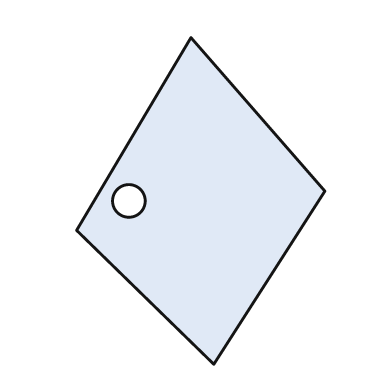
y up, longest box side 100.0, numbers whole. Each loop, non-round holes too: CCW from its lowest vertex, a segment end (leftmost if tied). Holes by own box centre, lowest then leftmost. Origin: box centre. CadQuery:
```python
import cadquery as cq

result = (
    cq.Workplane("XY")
    .moveTo(4.0, -50.0)
    .lineTo(38.0, 3.0)
    .lineTo(-3.0, 50.0)
    .lineTo(-38.0, -9.0)
    .close()
    .moveTo(-22.0, 0.0)
    .circle(5.0)
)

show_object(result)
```